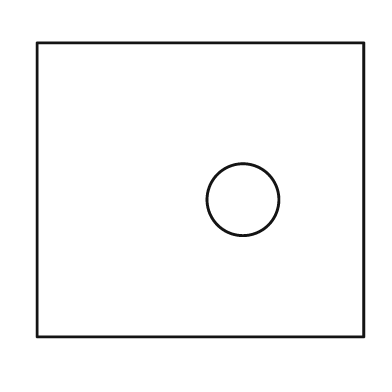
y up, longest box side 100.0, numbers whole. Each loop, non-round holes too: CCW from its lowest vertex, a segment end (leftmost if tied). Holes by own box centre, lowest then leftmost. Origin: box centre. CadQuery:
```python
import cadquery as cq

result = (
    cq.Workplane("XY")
    .moveTo(-50.0, -45.0)
    .lineTo(50.0, -45.0)
    .lineTo(50.0, 45.0)
    .lineTo(-50.0, 45.0)
    .close()
    .moveTo(13.0, -3.0)
    .circle(11.0)
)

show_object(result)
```